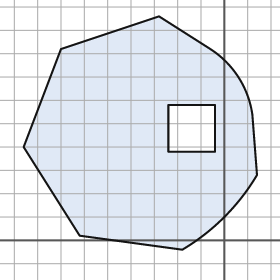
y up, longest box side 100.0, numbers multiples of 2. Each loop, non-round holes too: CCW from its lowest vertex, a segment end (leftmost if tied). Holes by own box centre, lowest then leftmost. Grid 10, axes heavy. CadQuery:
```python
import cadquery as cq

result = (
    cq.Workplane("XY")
    .moveTo(-18.0, -4.0)
    .threePointArc((0.0, 10.0), (14.0, 28.0))
    .lineTo(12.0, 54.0)
    .threePointArc((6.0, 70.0), (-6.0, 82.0))
    .lineTo(-28.0, 96.0)
    .lineTo(-70.0, 82.0)
    .lineTo(-86.0, 40.0)
    .lineTo(-62.0, 2.0)
    .close()
    .moveTo(-24.0, 38.0)
    .lineTo(-4.0, 38.0)
    .lineTo(-4.0, 58.0)
    .lineTo(-24.0, 58.0)
    .close()
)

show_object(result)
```